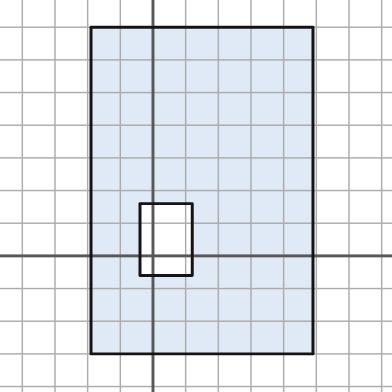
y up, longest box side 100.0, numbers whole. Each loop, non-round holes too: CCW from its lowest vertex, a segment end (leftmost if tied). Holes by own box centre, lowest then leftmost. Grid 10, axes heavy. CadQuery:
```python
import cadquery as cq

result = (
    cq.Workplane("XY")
    .moveTo(-19.0, -30.0)
    .lineTo(49.0, -30.0)
    .lineTo(49.0, 70.0)
    .lineTo(-19.0, 70.0)
    .close()
    .moveTo(-4.0, -6.0)
    .lineTo(12.0, -6.0)
    .lineTo(12.0, 16.0)
    .lineTo(-4.0, 16.0)
    .close()
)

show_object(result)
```